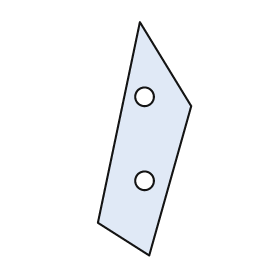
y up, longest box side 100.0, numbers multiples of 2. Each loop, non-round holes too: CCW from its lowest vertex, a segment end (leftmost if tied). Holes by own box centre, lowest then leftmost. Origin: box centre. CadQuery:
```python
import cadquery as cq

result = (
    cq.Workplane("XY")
    .moveTo(2.0, -50.0)
    .lineTo(20.0, 14.0)
    .lineTo(-2.0, 50.0)
    .lineTo(-20.0, -36.0)
    .close()
    .moveTo(0.0, -18.0)
    .circle(4.0)
    .moveTo(0.0, 18.0)
    .circle(4.0)
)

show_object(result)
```